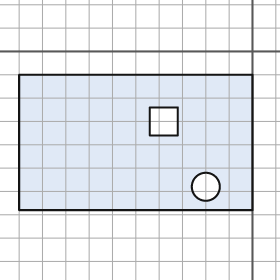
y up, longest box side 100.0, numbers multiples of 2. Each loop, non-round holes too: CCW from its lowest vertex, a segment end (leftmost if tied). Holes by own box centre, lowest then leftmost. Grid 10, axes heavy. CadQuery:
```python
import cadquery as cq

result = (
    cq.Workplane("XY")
    .moveTo(-100.0, -68.0)
    .lineTo(0.0, -68.0)
    .lineTo(0.0, -10.0)
    .lineTo(-100.0, -10.0)
    .close()
    .moveTo(-20.0, -58.0)
    .circle(6.0)
    .moveTo(-44.0, -36.0)
    .lineTo(-32.0, -36.0)
    .lineTo(-32.0, -24.0)
    .lineTo(-44.0, -24.0)
    .close()
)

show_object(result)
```